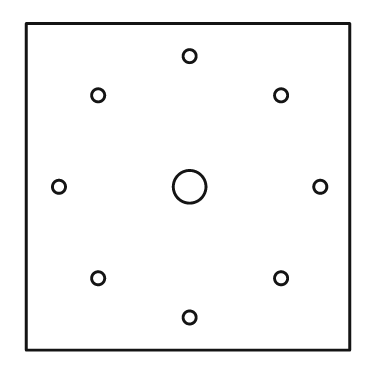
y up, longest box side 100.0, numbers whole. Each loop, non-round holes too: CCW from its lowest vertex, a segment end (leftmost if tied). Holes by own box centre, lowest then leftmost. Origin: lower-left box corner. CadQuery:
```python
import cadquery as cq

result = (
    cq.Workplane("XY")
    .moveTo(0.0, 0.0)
    .lineTo(99.0, 0.0)
    .lineTo(99.0, 100.0)
    .lineTo(0.0, 100.0)
    .close()
    .moveTo(50.0, 10.0)
    .circle(2.0)
    .moveTo(22.0, 22.0)
    .circle(2.0)
    .moveTo(78.0, 22.0)
    .circle(2.0)
    .moveTo(10.0, 50.0)
    .circle(2.0)
    .moveTo(50.0, 50.0)
    .circle(5.0)
    .moveTo(90.0, 50.0)
    .circle(2.0)
    .moveTo(22.0, 78.0)
    .circle(2.0)
    .moveTo(78.0, 78.0)
    .circle(2.0)
    .moveTo(50.0, 90.0)
    .circle(2.0)
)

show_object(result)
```